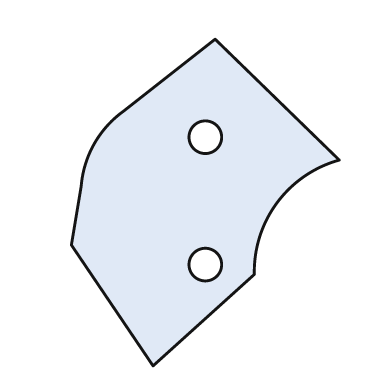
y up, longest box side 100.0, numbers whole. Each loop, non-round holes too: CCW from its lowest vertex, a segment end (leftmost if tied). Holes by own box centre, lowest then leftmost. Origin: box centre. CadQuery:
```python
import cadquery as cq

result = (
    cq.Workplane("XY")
    .moveTo(-16.0, -50.0)
    .lineTo(15.0, -22.0)
    .threePointArc((22.0, 0.0), (41.0, 13.0))
    .lineTo(3.0, 50.0)
    .lineTo(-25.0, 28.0)
    .threePointArc((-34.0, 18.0), (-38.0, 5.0))
    .lineTo(-41.0, -13.0)
    .close()
    .moveTo(0.0, -19.0)
    .circle(5.0)
    .moveTo(0.0, 20.0)
    .circle(5.0)
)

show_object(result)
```